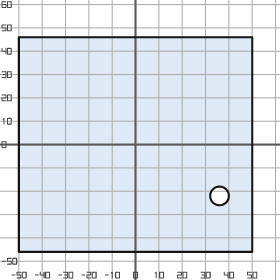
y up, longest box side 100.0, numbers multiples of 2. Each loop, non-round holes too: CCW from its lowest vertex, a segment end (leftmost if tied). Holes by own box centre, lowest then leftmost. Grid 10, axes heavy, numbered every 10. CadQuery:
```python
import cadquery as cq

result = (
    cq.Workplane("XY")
    .moveTo(-50.0, -46.0)
    .lineTo(50.0, -46.0)
    .lineTo(50.0, 46.0)
    .lineTo(-50.0, 46.0)
    .close()
    .moveTo(36.0, -22.0)
    .circle(4.0)
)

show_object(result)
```